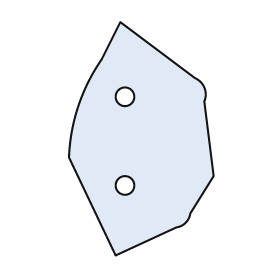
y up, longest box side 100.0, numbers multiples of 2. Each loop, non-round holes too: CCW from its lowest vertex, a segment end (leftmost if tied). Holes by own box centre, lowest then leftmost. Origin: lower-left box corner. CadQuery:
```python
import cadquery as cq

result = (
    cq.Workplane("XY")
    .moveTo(20.0, 0.0)
    .lineTo(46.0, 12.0)
    .threePointArc((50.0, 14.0), (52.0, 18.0))
    .lineTo(62.0, 34.0)
    .lineTo(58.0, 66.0)
    .threePointArc((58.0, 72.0), (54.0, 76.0))
    .lineTo(22.0, 100.0)
    .lineTo(14.0, 84.0)
    .threePointArc((4.0, 64.0), (0.0, 42.0))
    .close()
    .moveTo(24.0, 30.0)
    .circle(4.0)
    .moveTo(24.0, 68.0)
    .circle(4.0)
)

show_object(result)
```